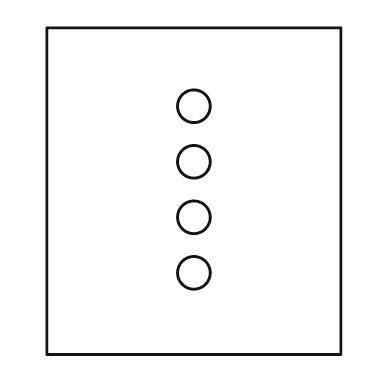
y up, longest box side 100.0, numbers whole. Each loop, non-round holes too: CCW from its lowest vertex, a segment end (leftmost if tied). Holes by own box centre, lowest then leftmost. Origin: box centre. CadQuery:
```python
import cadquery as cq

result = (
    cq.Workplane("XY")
    .moveTo(-45.0, -50.0)
    .lineTo(45.0, -50.0)
    .lineTo(45.0, 50.0)
    .lineTo(-45.0, 50.0)
    .close()
    .moveTo(0.0, -25.0)
    .circle(5.0)
    .moveTo(0.0, -8.0)
    .circle(5.0)
    .moveTo(0.0, 9.0)
    .circle(5.0)
    .moveTo(0.0, 26.0)
    .circle(5.0)
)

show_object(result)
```